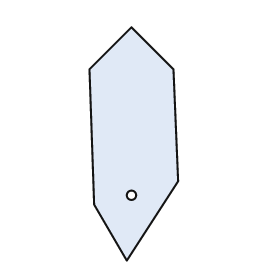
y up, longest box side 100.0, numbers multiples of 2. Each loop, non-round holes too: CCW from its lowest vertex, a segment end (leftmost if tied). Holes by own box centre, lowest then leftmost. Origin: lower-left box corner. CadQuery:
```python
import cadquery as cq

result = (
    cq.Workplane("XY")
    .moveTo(16.0, 0.0)
    .lineTo(38.0, 34.0)
    .lineTo(36.0, 82.0)
    .lineTo(18.0, 100.0)
    .lineTo(0.0, 82.0)
    .lineTo(2.0, 24.0)
    .close()
    .moveTo(18.0, 28.0)
    .circle(2.0)
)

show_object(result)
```